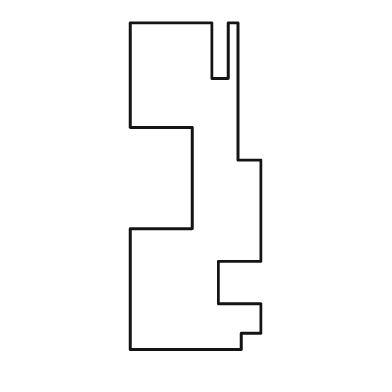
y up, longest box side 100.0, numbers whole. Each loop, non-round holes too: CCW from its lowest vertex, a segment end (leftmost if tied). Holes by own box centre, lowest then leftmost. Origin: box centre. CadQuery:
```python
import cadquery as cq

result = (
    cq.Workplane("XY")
    .moveTo(-20.0, -50.0)
    .lineTo(14.0, -50.0)
    .lineTo(14.0, -45.0)
    .lineTo(20.0, -45.0)
    .lineTo(20.0, -36.0)
    .lineTo(7.0, -36.0)
    .lineTo(7.0, -23.0)
    .lineTo(20.0, -23.0)
    .lineTo(20.0, 8.0)
    .lineTo(13.0, 8.0)
    .lineTo(13.0, 50.0)
    .lineTo(10.0, 50.0)
    .lineTo(10.0, 33.0)
    .lineTo(5.0, 33.0)
    .lineTo(5.0, 50.0)
    .lineTo(-20.0, 50.0)
    .lineTo(-20.0, 18.0)
    .lineTo(-1.0, 18.0)
    .lineTo(-1.0, -13.0)
    .lineTo(-20.0, -13.0)
    .close()
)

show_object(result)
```